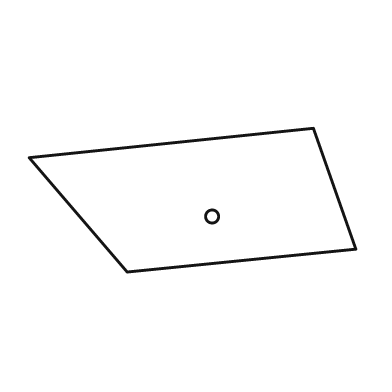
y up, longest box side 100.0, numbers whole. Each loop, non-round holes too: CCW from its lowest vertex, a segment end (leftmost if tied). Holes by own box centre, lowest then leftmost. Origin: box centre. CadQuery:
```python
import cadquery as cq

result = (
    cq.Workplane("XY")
    .moveTo(-20.0, -22.0)
    .lineTo(50.0, -15.0)
    .lineTo(37.0, 22.0)
    .lineTo(-50.0, 13.0)
    .close()
    .moveTo(6.0, -5.0)
    .circle(2.0)
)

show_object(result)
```